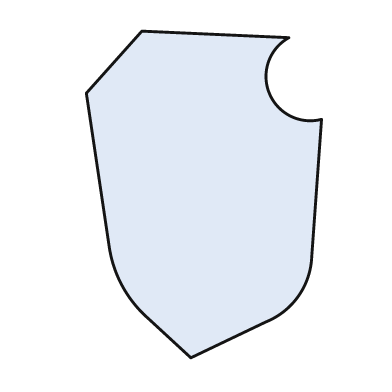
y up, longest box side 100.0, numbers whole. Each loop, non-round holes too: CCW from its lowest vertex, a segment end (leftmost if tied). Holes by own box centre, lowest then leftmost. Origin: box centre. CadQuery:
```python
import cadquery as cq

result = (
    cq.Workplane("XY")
    .moveTo(-4.0, -50.0)
    .lineTo(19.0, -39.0)
    .threePointArc((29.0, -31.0), (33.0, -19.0))
    .lineTo(36.0, 23.0)
    .threePointArc((20.0, 31.0), (26.0, 48.0))
    .lineTo(-19.0, 50.0)
    .lineTo(-36.0, 31.0)
    .lineTo(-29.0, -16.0)
    .threePointArc((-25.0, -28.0), (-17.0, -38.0))
    .close()
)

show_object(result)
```